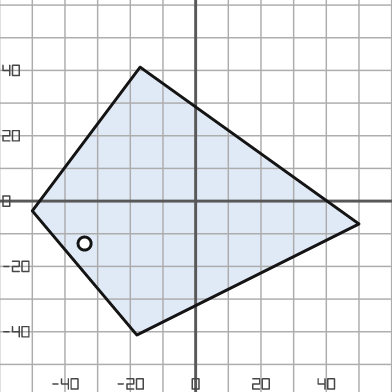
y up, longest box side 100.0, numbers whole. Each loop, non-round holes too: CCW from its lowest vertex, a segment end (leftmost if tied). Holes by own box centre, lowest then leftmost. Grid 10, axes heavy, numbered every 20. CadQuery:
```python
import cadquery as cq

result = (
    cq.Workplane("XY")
    .moveTo(-18.0, -41.0)
    .lineTo(50.0, -7.0)
    .lineTo(-17.0, 41.0)
    .lineTo(-50.0, -3.0)
    .close()
    .moveTo(-34.0, -13.0)
    .circle(2.0)
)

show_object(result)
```